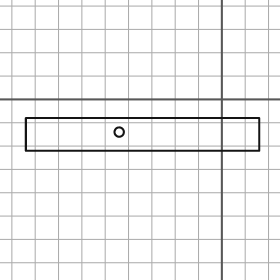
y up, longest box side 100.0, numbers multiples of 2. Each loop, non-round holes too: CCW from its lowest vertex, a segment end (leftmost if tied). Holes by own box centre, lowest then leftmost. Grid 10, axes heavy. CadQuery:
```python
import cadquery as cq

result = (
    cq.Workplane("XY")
    .moveTo(-84.0, -22.0)
    .lineTo(16.0, -22.0)
    .lineTo(16.0, -8.0)
    .lineTo(-84.0, -8.0)
    .close()
    .moveTo(-44.0, -14.0)
    .circle(2.0)
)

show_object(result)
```